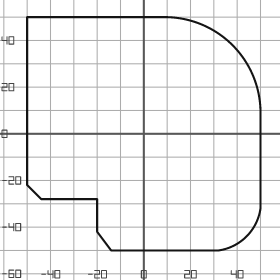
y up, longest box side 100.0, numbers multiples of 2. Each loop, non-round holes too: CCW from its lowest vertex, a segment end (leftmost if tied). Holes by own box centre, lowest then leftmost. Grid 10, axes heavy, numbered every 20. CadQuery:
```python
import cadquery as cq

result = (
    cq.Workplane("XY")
    .moveTo(-14.0, -50.0)
    .lineTo(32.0, -50.0)
    .threePointArc((44.0, -44.0), (50.0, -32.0))
    .lineTo(50.0, 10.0)
    .threePointArc((38.0, 38.0), (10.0, 50.0))
    .lineTo(-50.0, 50.0)
    .lineTo(-50.0, -22.0)
    .lineTo(-44.0, -28.0)
    .lineTo(-20.0, -28.0)
    .lineTo(-20.0, -42.0)
    .close()
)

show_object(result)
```